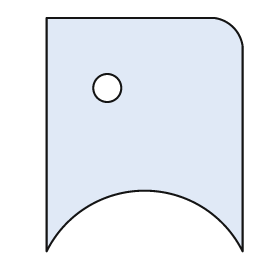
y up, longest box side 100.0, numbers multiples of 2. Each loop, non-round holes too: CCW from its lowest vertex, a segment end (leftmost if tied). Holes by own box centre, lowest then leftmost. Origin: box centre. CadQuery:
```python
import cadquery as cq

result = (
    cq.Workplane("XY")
    .moveTo(-42.0, -50.0)
    .threePointArc((0.0, -24.0), (42.0, -50.0))
    .lineTo(42.0, 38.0)
    .threePointArc((38.0, 46.0), (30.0, 50.0))
    .lineTo(-42.0, 50.0)
    .close()
    .moveTo(-16.0, 20.0)
    .circle(6.0)
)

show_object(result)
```